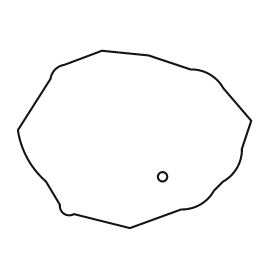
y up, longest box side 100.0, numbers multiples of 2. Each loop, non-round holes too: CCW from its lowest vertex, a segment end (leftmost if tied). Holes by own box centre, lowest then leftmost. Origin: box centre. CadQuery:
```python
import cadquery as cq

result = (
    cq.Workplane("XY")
    .moveTo(-2.0, -38.0)
    .lineTo(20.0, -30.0)
    .threePointArc((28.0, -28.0), (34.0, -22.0))
    .lineTo(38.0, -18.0)
    .threePointArc((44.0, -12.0), (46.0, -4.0))
    .lineTo(50.0, 8.0)
    .lineTo(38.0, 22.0)
    .threePointArc((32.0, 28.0), (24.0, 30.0))
    .lineTo(6.0, 36.0)
    .lineTo(-14.0, 38.0)
    .lineTo(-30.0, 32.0)
    .threePointArc((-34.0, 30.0), (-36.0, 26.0))
    .lineTo(-50.0, 4.0)
    .threePointArc((-46.0, -8.0), (-38.0, -18.0))
    .lineTo(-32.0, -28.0)
    .threePointArc((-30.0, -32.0), (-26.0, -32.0))
    .close()
    .moveTo(12.0, -16.0)
    .circle(2.0)
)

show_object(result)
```